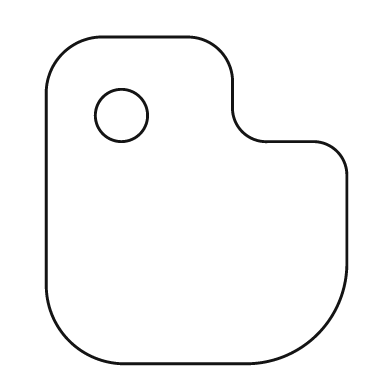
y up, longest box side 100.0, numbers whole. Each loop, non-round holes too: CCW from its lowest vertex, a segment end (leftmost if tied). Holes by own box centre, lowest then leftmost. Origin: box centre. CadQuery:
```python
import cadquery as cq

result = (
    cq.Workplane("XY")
    .moveTo(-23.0, -50.0)
    .lineTo(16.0, -50.0)
    .threePointArc((37.0, -41.0), (46.0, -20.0))
    .lineTo(46.0, 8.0)
    .threePointArc((43.0, 15.0), (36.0, 18.0))
    .lineTo(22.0, 18.0)
    .threePointArc((14.0, 21.0), (11.0, 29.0))
    .lineTo(11.0, 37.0)
    .threePointArc((7.0, 46.0), (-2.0, 50.0))
    .lineTo(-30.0, 50.0)
    .threePointArc((-41.0, 45.0), (-46.0, 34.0))
    .lineTo(-46.0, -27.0)
    .threePointArc((-39.0, -43.0), (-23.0, -50.0))
    .close()
    .moveTo(-23.0, 26.0)
    .circle(8.0)
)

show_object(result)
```